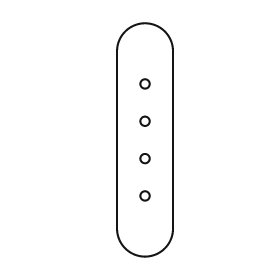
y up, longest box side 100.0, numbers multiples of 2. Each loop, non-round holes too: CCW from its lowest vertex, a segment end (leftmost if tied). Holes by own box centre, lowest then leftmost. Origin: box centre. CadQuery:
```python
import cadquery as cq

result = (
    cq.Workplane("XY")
    .moveTo(-12.0, -38.0)
    .threePointArc((0.0, -50.0), (12.0, -38.0))
    .lineTo(12.0, 38.0)
    .threePointArc((0.0, 50.0), (-12.0, 38.0))
    .close()
    .moveTo(0.0, -24.0)
    .circle(2.0)
    .moveTo(0.0, -8.0)
    .circle(2.0)
    .moveTo(0.0, 8.0)
    .circle(2.0)
    .moveTo(0.0, 24.0)
    .circle(2.0)
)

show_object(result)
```